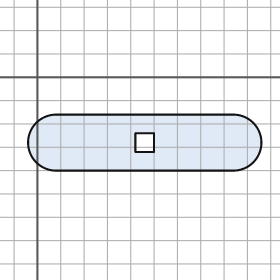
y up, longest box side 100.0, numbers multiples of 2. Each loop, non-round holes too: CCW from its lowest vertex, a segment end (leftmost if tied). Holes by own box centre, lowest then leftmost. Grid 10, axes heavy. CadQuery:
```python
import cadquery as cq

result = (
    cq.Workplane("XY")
    .moveTo(8.0, -40.0)
    .lineTo(84.0, -40.0)
    .threePointArc((96.0, -28.0), (84.0, -16.0))
    .lineTo(8.0, -16.0)
    .threePointArc((-4.0, -28.0), (8.0, -40.0))
    .close()
    .moveTo(42.0, -32.0)
    .lineTo(50.0, -32.0)
    .lineTo(50.0, -24.0)
    .lineTo(42.0, -24.0)
    .close()
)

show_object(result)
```